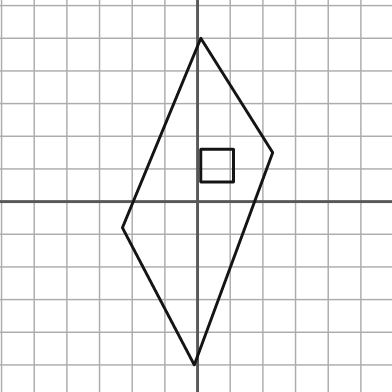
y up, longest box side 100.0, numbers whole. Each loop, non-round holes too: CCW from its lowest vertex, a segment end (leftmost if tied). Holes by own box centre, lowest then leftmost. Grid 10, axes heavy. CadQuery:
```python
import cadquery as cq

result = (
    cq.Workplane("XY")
    .moveTo(-1.0, -50.0)
    .lineTo(23.0, 15.0)
    .lineTo(1.0, 50.0)
    .lineTo(-23.0, -8.0)
    .close()
    .moveTo(1.0, 6.0)
    .lineTo(11.0, 6.0)
    .lineTo(11.0, 16.0)
    .lineTo(1.0, 16.0)
    .close()
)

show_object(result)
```